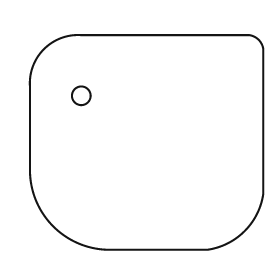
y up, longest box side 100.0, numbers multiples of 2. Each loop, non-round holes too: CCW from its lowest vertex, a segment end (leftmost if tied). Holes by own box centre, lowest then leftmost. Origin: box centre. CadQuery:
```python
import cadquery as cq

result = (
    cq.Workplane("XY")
    .moveTo(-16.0, -46.0)
    .lineTo(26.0, -46.0)
    .threePointArc((42.0, -38.0), (50.0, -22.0))
    .lineTo(50.0, 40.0)
    .threePointArc((48.0, 44.0), (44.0, 46.0))
    .lineTo(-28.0, 46.0)
    .threePointArc((-44.0, 40.0), (-50.0, 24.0))
    .lineTo(-50.0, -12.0)
    .threePointArc((-40.0, -36.0), (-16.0, -46.0))
    .close()
    .moveTo(-28.0, 20.0)
    .circle(4.0)
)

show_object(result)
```